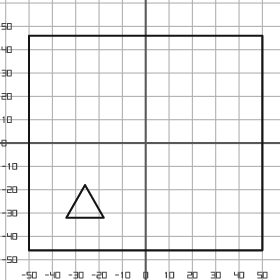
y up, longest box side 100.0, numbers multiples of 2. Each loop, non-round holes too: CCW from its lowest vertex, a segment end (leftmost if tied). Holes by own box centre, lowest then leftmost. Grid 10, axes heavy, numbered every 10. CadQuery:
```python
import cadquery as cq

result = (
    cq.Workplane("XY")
    .moveTo(-50.0, -46.0)
    .lineTo(50.0, -46.0)
    .lineTo(50.0, 46.0)
    .lineTo(-50.0, 46.0)
    .close()
    .moveTo(-34.0, -32.0)
    .lineTo(-18.0, -32.0)
    .lineTo(-26.0, -18.0)
    .close()
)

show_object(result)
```